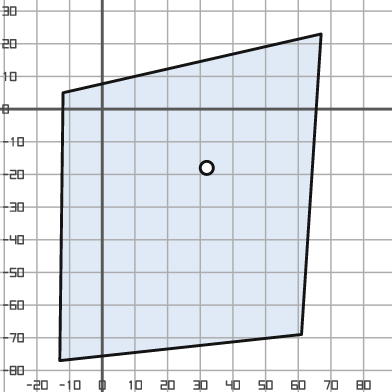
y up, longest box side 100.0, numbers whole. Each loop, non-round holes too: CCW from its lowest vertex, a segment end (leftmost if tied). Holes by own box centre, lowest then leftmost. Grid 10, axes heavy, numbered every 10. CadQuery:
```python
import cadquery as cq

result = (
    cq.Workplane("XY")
    .moveTo(-13.0, -77.0)
    .lineTo(61.0, -69.0)
    .lineTo(67.0, 23.0)
    .lineTo(-12.0, 5.0)
    .close()
    .moveTo(32.0, -18.0)
    .circle(2.0)
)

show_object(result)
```